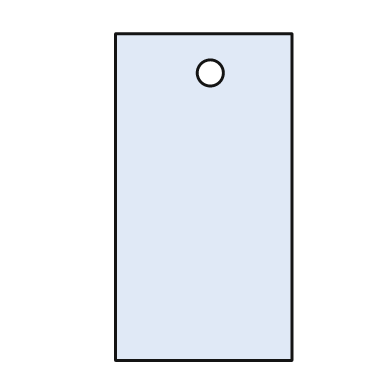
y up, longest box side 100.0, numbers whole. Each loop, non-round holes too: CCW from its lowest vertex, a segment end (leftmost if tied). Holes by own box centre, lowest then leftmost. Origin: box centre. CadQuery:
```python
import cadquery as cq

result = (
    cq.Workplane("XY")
    .moveTo(-27.0, -50.0)
    .lineTo(27.0, -50.0)
    .lineTo(27.0, 50.0)
    .lineTo(-27.0, 50.0)
    .close()
    .moveTo(2.0, 38.0)
    .circle(4.0)
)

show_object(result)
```